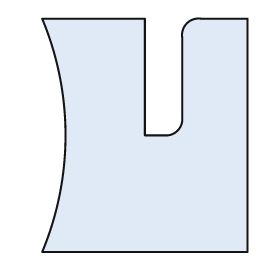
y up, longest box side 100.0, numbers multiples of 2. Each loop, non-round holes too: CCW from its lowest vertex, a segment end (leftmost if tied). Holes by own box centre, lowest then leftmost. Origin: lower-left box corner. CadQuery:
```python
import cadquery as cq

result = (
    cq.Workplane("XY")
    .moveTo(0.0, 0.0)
    .lineTo(88.0, 0.0)
    .lineTo(88.0, 100.0)
    .lineTo(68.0, 100.0)
    .threePointArc((62.0, 98.0), (60.0, 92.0))
    .lineTo(60.0, 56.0)
    .threePointArc((58.0, 52.0), (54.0, 50.0))
    .lineTo(44.0, 50.0)
    .lineTo(44.0, 100.0)
    .lineTo(0.0, 100.0)
    .threePointArc((10.0, 50.0), (0.0, 0.0))
    .close()
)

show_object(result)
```